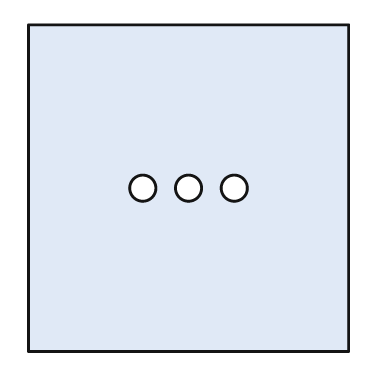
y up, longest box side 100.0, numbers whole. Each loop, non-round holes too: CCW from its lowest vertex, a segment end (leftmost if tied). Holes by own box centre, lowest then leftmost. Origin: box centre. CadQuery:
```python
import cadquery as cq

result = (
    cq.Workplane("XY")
    .moveTo(-49.0, -50.0)
    .lineTo(49.0, -50.0)
    .lineTo(49.0, 50.0)
    .lineTo(-49.0, 50.0)
    .close()
    .moveTo(-14.0, 0.0)
    .circle(4.0)
    .moveTo(0.0, 0.0)
    .circle(4.0)
    .moveTo(14.0, 0.0)
    .circle(4.0)
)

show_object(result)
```